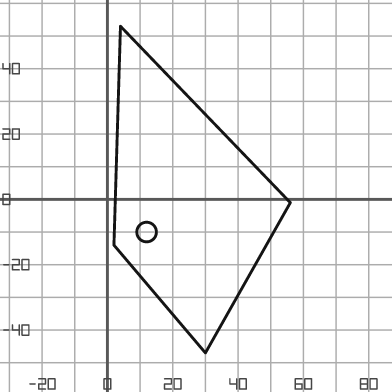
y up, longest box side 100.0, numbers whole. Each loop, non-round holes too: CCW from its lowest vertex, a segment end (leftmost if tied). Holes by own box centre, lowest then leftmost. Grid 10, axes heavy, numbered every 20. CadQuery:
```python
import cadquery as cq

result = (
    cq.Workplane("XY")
    .moveTo(30.0, -47.0)
    .lineTo(56.0, -1.0)
    .lineTo(4.0, 53.0)
    .lineTo(2.0, -14.0)
    .close()
    .moveTo(12.0, -10.0)
    .circle(3.0)
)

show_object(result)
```